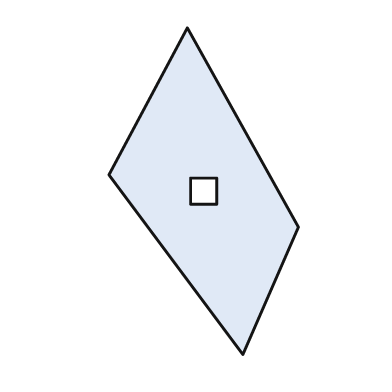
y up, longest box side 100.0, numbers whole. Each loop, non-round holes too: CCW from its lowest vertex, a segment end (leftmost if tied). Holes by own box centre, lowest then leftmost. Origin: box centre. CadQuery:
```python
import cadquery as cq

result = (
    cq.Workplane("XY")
    .moveTo(12.0, -50.0)
    .lineTo(29.0, -11.0)
    .lineTo(-5.0, 50.0)
    .lineTo(-29.0, 5.0)
    .close()
    .moveTo(-4.0, -4.0)
    .lineTo(4.0, -4.0)
    .lineTo(4.0, 4.0)
    .lineTo(-4.0, 4.0)
    .close()
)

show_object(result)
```